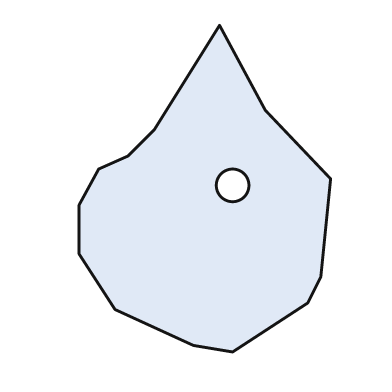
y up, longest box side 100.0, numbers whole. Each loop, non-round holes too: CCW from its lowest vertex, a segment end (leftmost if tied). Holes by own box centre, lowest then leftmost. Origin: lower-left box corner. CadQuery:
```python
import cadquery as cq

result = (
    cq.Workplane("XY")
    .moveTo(47.0, 0.0)
    .lineTo(70.0, 15.0)
    .lineTo(74.0, 23.0)
    .lineTo(77.0, 53.0)
    .lineTo(57.0, 74.0)
    .lineTo(43.0, 100.0)
    .lineTo(23.0, 68.0)
    .lineTo(15.0, 60.0)
    .lineTo(6.0, 56.0)
    .lineTo(0.0, 45.0)
    .lineTo(0.0, 30.0)
    .lineTo(11.0, 13.0)
    .lineTo(35.0, 2.0)
    .close()
    .moveTo(47.0, 51.0)
    .circle(5.0)
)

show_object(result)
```